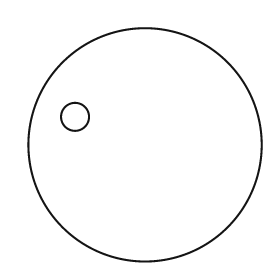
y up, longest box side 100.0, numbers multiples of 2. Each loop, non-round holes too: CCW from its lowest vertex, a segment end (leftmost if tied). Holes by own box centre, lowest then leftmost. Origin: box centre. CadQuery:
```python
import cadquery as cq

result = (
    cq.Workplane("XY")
    .moveTo(0.0, 0.0)
    .circle(50.0)
    .moveTo(-30.0, 12.0)
    .circle(6.0)
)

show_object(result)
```